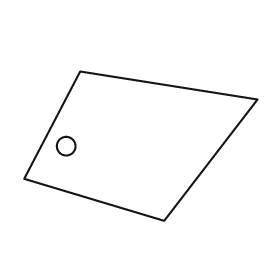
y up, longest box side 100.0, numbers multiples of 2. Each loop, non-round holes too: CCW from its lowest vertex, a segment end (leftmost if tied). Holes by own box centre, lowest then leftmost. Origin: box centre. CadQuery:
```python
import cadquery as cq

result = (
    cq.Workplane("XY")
    .moveTo(10.0, -32.0)
    .lineTo(50.0, 20.0)
    .lineTo(-26.0, 32.0)
    .lineTo(-50.0, -14.0)
    .close()
    .moveTo(-32.0, 0.0)
    .circle(4.0)
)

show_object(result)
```